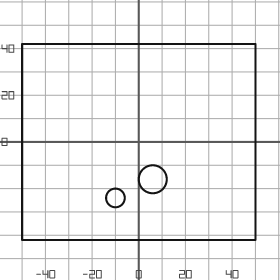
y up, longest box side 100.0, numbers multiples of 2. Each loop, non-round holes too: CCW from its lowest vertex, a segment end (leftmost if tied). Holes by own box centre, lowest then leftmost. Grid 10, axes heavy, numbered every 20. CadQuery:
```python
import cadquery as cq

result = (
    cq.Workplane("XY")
    .moveTo(-50.0, -42.0)
    .lineTo(50.0, -42.0)
    .lineTo(50.0, 42.0)
    .lineTo(-50.0, 42.0)
    .close()
    .moveTo(-10.0, -24.0)
    .circle(4.0)
    .moveTo(6.0, -16.0)
    .circle(6.0)
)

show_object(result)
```